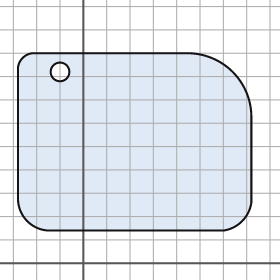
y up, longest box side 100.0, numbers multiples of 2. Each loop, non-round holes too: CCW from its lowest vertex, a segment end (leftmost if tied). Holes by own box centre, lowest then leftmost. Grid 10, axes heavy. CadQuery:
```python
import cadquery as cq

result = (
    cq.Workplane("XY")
    .moveTo(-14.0, 14.0)
    .lineTo(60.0, 14.0)
    .threePointArc((68.0, 18.0), (72.0, 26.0))
    .lineTo(72.0, 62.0)
    .threePointArc((64.0, 82.0), (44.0, 90.0))
    .lineTo(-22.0, 90.0)
    .threePointArc((-26.0, 88.0), (-28.0, 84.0))
    .lineTo(-28.0, 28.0)
    .threePointArc((-24.0, 18.0), (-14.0, 14.0))
    .close()
    .moveTo(-10.0, 82.0)
    .circle(4.0)
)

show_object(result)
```